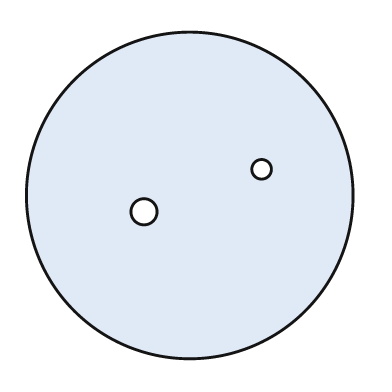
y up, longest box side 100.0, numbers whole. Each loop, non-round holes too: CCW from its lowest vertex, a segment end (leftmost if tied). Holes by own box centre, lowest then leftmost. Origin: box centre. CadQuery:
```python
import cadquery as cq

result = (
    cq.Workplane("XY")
    .moveTo(0.0, 0.0)
    .circle(50.0)
    .moveTo(-14.0, -5.0)
    .circle(4.0)
    .moveTo(22.0, 8.0)
    .circle(3.0)
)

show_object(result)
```